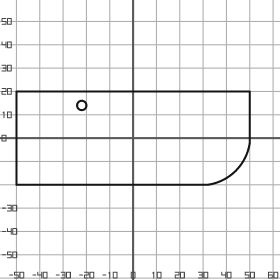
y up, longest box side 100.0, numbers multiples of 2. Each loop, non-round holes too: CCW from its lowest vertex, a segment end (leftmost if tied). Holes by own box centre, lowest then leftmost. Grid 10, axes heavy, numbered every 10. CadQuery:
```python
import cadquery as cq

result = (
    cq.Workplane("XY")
    .moveTo(-50.0, -20.0)
    .lineTo(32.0, -20.0)
    .threePointArc((44.0, -14.0), (50.0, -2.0))
    .lineTo(50.0, 20.0)
    .lineTo(-50.0, 20.0)
    .close()
    .moveTo(-22.0, 14.0)
    .circle(2.0)
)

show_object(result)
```